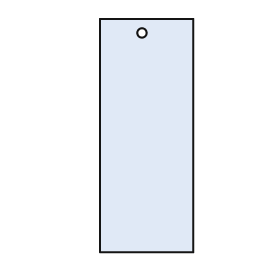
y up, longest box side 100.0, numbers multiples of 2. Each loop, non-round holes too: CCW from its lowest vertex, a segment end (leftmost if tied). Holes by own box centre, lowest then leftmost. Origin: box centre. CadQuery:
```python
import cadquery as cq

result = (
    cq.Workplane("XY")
    .moveTo(-20.0, -50.0)
    .lineTo(20.0, -50.0)
    .lineTo(20.0, 50.0)
    .lineTo(-20.0, 50.0)
    .close()
    .moveTo(-2.0, 44.0)
    .circle(2.0)
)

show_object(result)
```